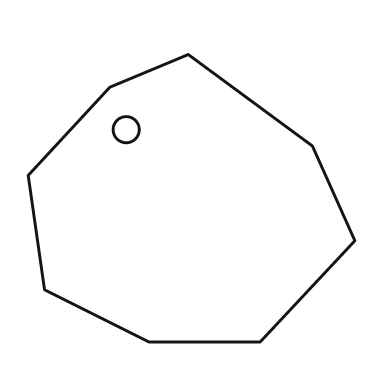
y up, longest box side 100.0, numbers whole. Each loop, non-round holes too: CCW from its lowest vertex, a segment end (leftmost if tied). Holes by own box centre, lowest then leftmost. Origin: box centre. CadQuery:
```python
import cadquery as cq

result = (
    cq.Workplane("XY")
    .moveTo(-13.0, -44.0)
    .lineTo(21.0, -44.0)
    .lineTo(50.0, -13.0)
    .lineTo(37.0, 16.0)
    .lineTo(-1.0, 44.0)
    .lineTo(-25.0, 34.0)
    .lineTo(-50.0, 7.0)
    .lineTo(-45.0, -28.0)
    .close()
    .moveTo(-20.0, 21.0)
    .circle(4.0)
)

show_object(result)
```